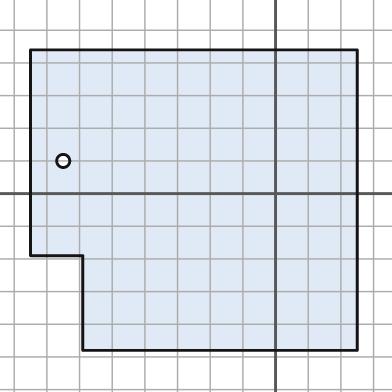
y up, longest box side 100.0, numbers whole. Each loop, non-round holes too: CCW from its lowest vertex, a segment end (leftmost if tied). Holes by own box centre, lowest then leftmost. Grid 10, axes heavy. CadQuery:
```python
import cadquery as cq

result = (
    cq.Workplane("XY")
    .moveTo(-59.0, -48.0)
    .lineTo(25.0, -48.0)
    .lineTo(25.0, 44.0)
    .lineTo(-75.0, 44.0)
    .lineTo(-75.0, -19.0)
    .lineTo(-59.0, -19.0)
    .close()
    .moveTo(-65.0, 10.0)
    .circle(2.0)
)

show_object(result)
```